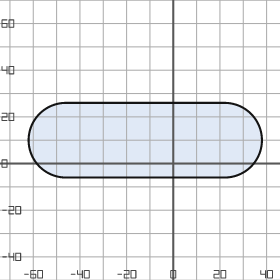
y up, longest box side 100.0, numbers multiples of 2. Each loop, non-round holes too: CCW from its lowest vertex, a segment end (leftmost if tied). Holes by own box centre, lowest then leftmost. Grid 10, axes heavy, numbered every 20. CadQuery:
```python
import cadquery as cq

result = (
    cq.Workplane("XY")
    .moveTo(-46.0, -6.0)
    .lineTo(22.0, -6.0)
    .threePointArc((38.0, 10.0), (22.0, 26.0))
    .lineTo(-46.0, 26.0)
    .threePointArc((-62.0, 10.0), (-46.0, -6.0))
    .close()
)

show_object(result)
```